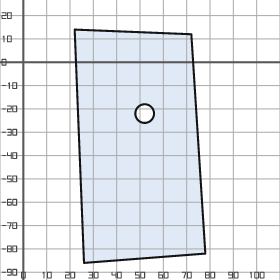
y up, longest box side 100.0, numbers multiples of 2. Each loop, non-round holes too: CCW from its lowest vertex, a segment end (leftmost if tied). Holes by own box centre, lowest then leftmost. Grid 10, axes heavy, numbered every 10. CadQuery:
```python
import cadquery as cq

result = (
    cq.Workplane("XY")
    .moveTo(26.0, -86.0)
    .lineTo(78.0, -82.0)
    .lineTo(72.0, 12.0)
    .lineTo(22.0, 14.0)
    .close()
    .moveTo(52.0, -22.0)
    .circle(4.0)
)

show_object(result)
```